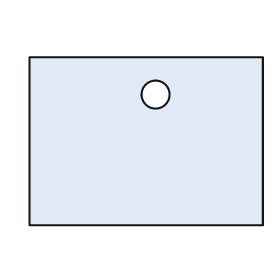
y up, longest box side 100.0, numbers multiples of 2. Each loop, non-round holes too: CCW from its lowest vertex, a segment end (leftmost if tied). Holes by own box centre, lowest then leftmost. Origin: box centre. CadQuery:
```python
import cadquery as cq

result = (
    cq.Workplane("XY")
    .moveTo(-50.0, -36.0)
    .lineTo(50.0, -36.0)
    .lineTo(50.0, 36.0)
    .lineTo(-50.0, 36.0)
    .close()
    .moveTo(4.0, 20.0)
    .circle(6.0)
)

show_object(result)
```